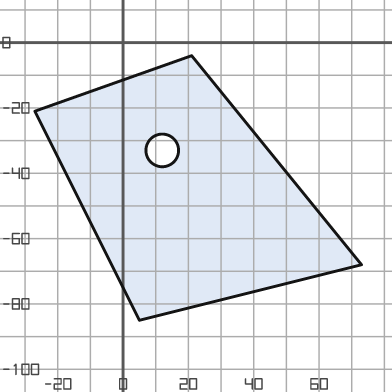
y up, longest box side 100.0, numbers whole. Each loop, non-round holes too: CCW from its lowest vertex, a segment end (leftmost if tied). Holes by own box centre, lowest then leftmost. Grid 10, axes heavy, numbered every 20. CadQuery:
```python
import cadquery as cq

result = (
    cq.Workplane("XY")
    .moveTo(5.0, -85.0)
    .lineTo(73.0, -68.0)
    .lineTo(21.0, -4.0)
    .lineTo(-27.0, -21.0)
    .close()
    .moveTo(12.0, -33.0)
    .circle(5.0)
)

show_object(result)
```